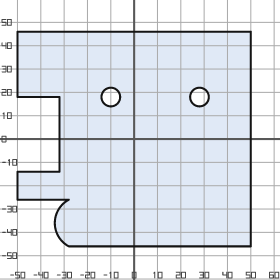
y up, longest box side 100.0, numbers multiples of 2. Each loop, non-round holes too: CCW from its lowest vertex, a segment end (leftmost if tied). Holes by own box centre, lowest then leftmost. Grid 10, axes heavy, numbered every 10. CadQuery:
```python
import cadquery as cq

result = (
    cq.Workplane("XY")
    .moveTo(-28.0, -46.0)
    .lineTo(50.0, -46.0)
    .lineTo(50.0, 46.0)
    .lineTo(-50.0, 46.0)
    .lineTo(-50.0, 18.0)
    .lineTo(-32.0, 18.0)
    .lineTo(-32.0, -14.0)
    .lineTo(-50.0, -14.0)
    .lineTo(-50.0, -26.0)
    .lineTo(-28.0, -26.0)
    .threePointArc((-34.0, -36.0), (-28.0, -46.0))
    .close()
    .moveTo(-10.0, 18.0)
    .circle(4.0)
    .moveTo(28.0, 18.0)
    .circle(4.0)
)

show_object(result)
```